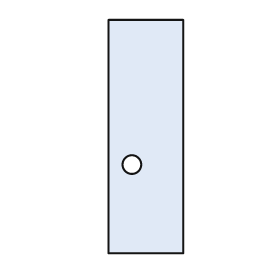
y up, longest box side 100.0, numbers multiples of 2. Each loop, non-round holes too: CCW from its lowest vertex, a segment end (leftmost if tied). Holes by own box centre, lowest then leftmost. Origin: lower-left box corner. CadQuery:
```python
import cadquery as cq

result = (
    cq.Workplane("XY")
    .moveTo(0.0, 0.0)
    .lineTo(32.0, 0.0)
    .lineTo(32.0, 100.0)
    .lineTo(0.0, 100.0)
    .close()
    .moveTo(10.0, 38.0)
    .circle(4.0)
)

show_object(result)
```